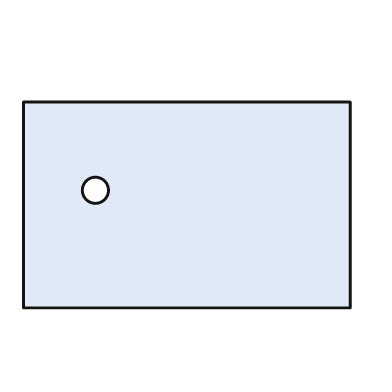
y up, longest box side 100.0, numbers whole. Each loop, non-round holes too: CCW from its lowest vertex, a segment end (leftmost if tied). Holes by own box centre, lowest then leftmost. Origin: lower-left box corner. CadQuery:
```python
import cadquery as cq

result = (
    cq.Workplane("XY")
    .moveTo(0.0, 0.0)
    .lineTo(100.0, 0.0)
    .lineTo(100.0, 63.0)
    .lineTo(0.0, 63.0)
    .close()
    .moveTo(22.0, 36.0)
    .circle(4.0)
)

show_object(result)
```